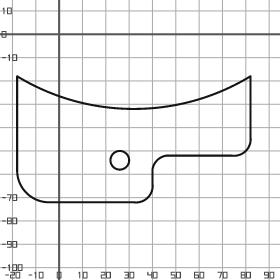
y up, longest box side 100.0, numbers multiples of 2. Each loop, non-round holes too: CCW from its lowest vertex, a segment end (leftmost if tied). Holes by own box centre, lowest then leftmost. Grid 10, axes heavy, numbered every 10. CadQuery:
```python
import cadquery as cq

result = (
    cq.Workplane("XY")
    .moveTo(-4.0, -72.0)
    .lineTo(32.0, -72.0)
    .threePointArc((38.0, -70.0), (40.0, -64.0))
    .lineTo(40.0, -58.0)
    .threePointArc((42.0, -54.0), (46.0, -52.0))
    .lineTo(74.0, -52.0)
    .threePointArc((80.0, -50.0), (82.0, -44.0))
    .lineTo(82.0, -18.0)
    .threePointArc((32.0, -32.0), (-18.0, -18.0))
    .lineTo(-18.0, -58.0)
    .threePointArc((-14.0, -68.0), (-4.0, -72.0))
    .close()
    .moveTo(26.0, -54.0)
    .circle(4.0)
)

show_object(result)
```